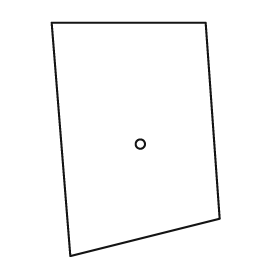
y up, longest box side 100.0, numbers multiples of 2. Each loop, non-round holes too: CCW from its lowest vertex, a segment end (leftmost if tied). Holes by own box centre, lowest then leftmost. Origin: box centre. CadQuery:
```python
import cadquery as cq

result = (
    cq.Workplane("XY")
    .moveTo(-28.0, -50.0)
    .lineTo(36.0, -34.0)
    .lineTo(30.0, 50.0)
    .lineTo(-36.0, 50.0)
    .close()
    .moveTo(2.0, -2.0)
    .circle(2.0)
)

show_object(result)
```